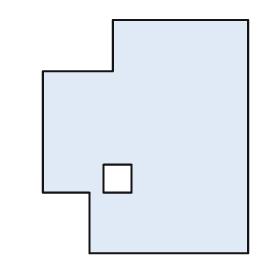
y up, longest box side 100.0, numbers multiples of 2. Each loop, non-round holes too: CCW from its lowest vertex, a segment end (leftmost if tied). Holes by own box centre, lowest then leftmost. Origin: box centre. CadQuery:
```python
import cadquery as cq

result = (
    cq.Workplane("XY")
    .moveTo(-24.0, -50.0)
    .lineTo(44.0, -50.0)
    .lineTo(44.0, 50.0)
    .lineTo(-14.0, 50.0)
    .lineTo(-14.0, 28.0)
    .lineTo(-44.0, 28.0)
    .lineTo(-44.0, -24.0)
    .lineTo(-24.0, -24.0)
    .close()
    .moveTo(-18.0, -24.0)
    .lineTo(-6.0, -24.0)
    .lineTo(-6.0, -12.0)
    .lineTo(-18.0, -12.0)
    .close()
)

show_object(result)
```